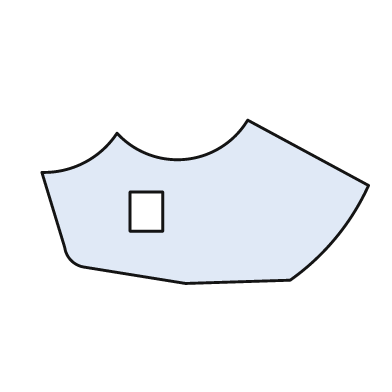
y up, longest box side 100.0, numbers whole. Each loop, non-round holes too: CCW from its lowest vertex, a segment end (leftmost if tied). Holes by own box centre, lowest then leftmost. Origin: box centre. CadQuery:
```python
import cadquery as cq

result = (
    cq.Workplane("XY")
    .moveTo(-6.0, -25.0)
    .lineTo(26.0, -24.0)
    .threePointArc((40.0, -11.0), (50.0, 5.0))
    .lineTo(13.0, 25.0)
    .threePointArc((-6.0, 13.0), (-27.0, 21.0))
    .threePointArc((-37.0, 12.0), (-50.0, 9.0))
    .lineTo(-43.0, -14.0)
    .threePointArc((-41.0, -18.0), (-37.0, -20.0))
    .close()
    .moveTo(-23.0, -9.0)
    .lineTo(-13.0, -9.0)
    .lineTo(-13.0, 3.0)
    .lineTo(-23.0, 3.0)
    .close()
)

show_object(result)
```